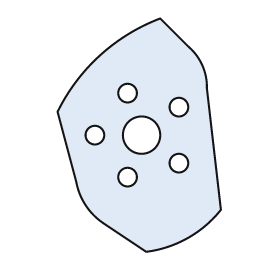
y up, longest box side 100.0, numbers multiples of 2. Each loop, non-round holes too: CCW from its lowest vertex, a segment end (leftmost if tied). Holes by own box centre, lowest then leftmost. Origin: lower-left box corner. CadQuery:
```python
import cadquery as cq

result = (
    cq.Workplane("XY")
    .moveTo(38.0, 0.0)
    .threePointArc((56.0, 6.0), (70.0, 18.0))
    .lineTo(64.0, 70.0)
    .threePointArc((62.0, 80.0), (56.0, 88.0))
    .lineTo(44.0, 100.0)
    .threePointArc((18.0, 84.0), (0.0, 60.0))
    .lineTo(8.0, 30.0)
    .threePointArc((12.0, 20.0), (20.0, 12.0))
    .close()
    .moveTo(30.0, 32.0)
    .circle(4.0)
    .moveTo(52.0, 38.0)
    .circle(4.0)
    .moveTo(16.0, 50.0)
    .circle(4.0)
    .moveTo(36.0, 50.0)
    .circle(8.0)
    .moveTo(52.0, 62.0)
    .circle(4.0)
    .moveTo(30.0, 68.0)
    .circle(4.0)
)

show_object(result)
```